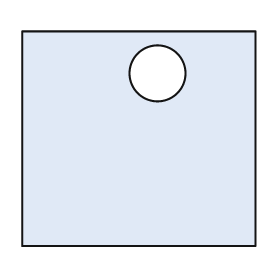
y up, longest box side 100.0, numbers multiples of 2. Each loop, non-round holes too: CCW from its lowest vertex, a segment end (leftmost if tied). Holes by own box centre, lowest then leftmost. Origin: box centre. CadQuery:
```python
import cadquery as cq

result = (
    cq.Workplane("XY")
    .moveTo(-50.0, -46.0)
    .lineTo(50.0, -46.0)
    .lineTo(50.0, 46.0)
    .lineTo(-50.0, 46.0)
    .close()
    .moveTo(8.0, 28.0)
    .circle(12.0)
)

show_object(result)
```